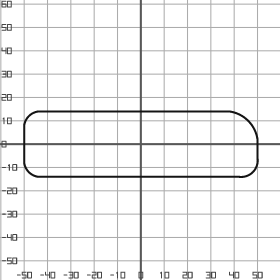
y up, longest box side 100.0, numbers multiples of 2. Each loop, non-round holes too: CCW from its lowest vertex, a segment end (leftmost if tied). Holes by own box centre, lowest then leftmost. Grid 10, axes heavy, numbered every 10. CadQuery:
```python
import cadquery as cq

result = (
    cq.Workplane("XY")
    .moveTo(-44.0, -14.0)
    .lineTo(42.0, -14.0)
    .threePointArc((48.0, -12.0), (50.0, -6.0))
    .lineTo(50.0, 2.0)
    .threePointArc((46.0, 10.0), (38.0, 14.0))
    .lineTo(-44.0, 14.0)
    .threePointArc((-48.0, 12.0), (-50.0, 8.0))
    .lineTo(-50.0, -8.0)
    .threePointArc((-48.0, -12.0), (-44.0, -14.0))
    .close()
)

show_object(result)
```